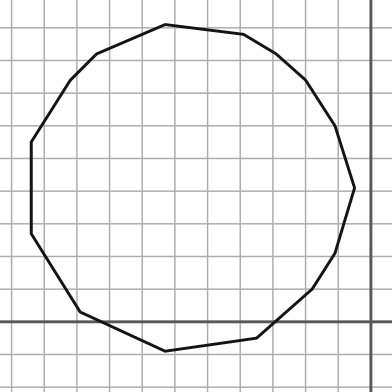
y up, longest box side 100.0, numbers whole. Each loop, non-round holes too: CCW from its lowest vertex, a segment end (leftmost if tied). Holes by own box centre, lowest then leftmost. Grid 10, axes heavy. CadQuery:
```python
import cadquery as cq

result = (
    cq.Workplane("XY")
    .moveTo(-63.0, -9.0)
    .lineTo(-35.0, -5.0)
    .lineTo(-18.0, 10.0)
    .lineTo(-11.0, 21.0)
    .lineTo(-5.0, 41.0)
    .lineTo(-11.0, 60.0)
    .lineTo(-20.0, 74.0)
    .lineTo(-29.0, 82.0)
    .lineTo(-39.0, 88.0)
    .lineTo(-63.0, 91.0)
    .lineTo(-84.0, 82.0)
    .lineTo(-92.0, 74.0)
    .lineTo(-104.0, 55.0)
    .lineTo(-104.0, 27.0)
    .lineTo(-89.0, 3.0)
    .close()
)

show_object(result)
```